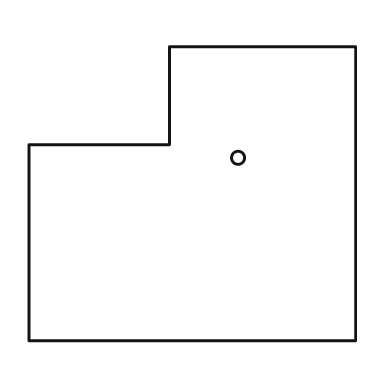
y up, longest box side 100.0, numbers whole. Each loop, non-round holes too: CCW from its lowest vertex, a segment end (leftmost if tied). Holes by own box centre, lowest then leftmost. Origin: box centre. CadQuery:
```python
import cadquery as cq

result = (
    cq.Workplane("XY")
    .moveTo(-50.0, -45.0)
    .lineTo(50.0, -45.0)
    .lineTo(50.0, 45.0)
    .lineTo(-7.0, 45.0)
    .lineTo(-7.0, 15.0)
    .lineTo(-50.0, 15.0)
    .close()
    .moveTo(14.0, 11.0)
    .circle(2.0)
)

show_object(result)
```